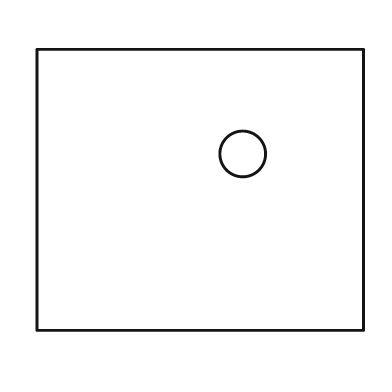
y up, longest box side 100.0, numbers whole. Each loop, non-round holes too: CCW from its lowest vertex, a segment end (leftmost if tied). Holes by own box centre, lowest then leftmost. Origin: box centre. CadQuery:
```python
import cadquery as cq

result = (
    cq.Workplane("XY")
    .moveTo(-50.0, -43.0)
    .lineTo(50.0, -43.0)
    .lineTo(50.0, 43.0)
    .lineTo(-50.0, 43.0)
    .close()
    .moveTo(13.0, 11.0)
    .circle(7.0)
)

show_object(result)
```